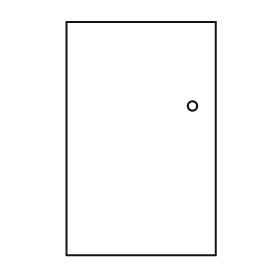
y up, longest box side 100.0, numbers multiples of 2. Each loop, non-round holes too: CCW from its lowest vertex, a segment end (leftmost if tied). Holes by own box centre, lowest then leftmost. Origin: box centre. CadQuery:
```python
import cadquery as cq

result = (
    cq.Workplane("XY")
    .moveTo(-32.0, -50.0)
    .lineTo(32.0, -50.0)
    .lineTo(32.0, 50.0)
    .lineTo(-32.0, 50.0)
    .close()
    .moveTo(22.0, 14.0)
    .circle(2.0)
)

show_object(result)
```